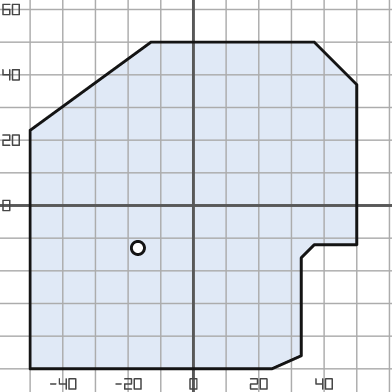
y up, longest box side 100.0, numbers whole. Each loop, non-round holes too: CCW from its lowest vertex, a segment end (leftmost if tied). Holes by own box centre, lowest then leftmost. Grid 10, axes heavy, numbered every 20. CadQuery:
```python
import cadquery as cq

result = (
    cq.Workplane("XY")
    .moveTo(-50.0, -50.0)
    .lineTo(24.0, -50.0)
    .lineTo(33.0, -46.0)
    .lineTo(33.0, -16.0)
    .lineTo(37.0, -12.0)
    .lineTo(50.0, -12.0)
    .lineTo(50.0, 37.0)
    .lineTo(37.0, 50.0)
    .lineTo(-13.0, 50.0)
    .lineTo(-50.0, 23.0)
    .close()
    .moveTo(-17.0, -13.0)
    .circle(2.0)
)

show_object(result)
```